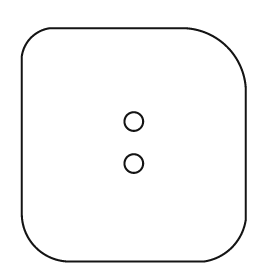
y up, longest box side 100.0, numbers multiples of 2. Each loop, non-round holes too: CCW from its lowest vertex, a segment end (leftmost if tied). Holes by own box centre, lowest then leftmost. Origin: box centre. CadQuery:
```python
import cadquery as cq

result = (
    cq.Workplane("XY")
    .moveTo(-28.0, -50.0)
    .lineTo(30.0, -50.0)
    .threePointArc((42.0, -44.0), (48.0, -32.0))
    .lineTo(48.0, 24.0)
    .threePointArc((40.0, 42.0), (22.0, 50.0))
    .lineTo(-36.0, 50.0)
    .threePointArc((-44.0, 46.0), (-48.0, 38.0))
    .lineTo(-48.0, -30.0)
    .threePointArc((-42.0, -44.0), (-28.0, -50.0))
    .close()
    .moveTo(0.0, -8.0)
    .circle(4.0)
    .moveTo(0.0, 10.0)
    .circle(4.0)
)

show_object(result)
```